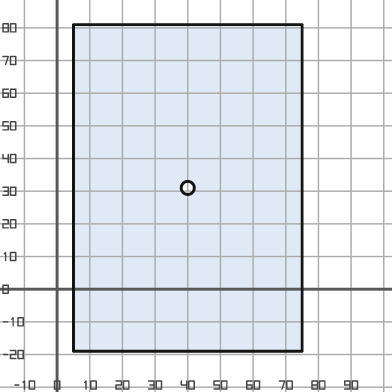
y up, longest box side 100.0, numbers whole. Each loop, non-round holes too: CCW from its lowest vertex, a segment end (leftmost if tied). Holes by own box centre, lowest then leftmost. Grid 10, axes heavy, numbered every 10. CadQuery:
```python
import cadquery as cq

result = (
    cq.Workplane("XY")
    .moveTo(5.0, -19.0)
    .lineTo(75.0, -19.0)
    .lineTo(75.0, 81.0)
    .lineTo(5.0, 81.0)
    .close()
    .moveTo(40.0, 31.0)
    .circle(2.0)
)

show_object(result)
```